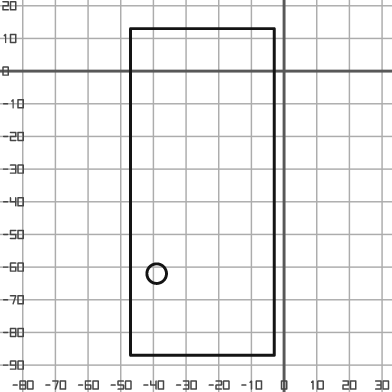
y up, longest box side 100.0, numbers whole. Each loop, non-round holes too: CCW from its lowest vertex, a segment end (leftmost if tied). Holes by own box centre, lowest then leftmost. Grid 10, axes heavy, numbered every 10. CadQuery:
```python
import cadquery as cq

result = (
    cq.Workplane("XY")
    .moveTo(-47.0, -87.0)
    .lineTo(-3.0, -87.0)
    .lineTo(-3.0, 13.0)
    .lineTo(-47.0, 13.0)
    .close()
    .moveTo(-39.0, -62.0)
    .circle(3.0)
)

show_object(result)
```